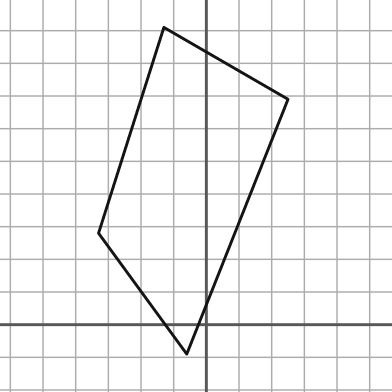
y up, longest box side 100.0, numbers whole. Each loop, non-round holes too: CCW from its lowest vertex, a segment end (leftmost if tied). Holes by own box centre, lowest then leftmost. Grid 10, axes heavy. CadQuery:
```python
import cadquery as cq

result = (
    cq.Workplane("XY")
    .moveTo(-6.0, -9.0)
    .lineTo(25.0, 69.0)
    .lineTo(-13.0, 91.0)
    .lineTo(-33.0, 28.0)
    .close()
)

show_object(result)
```